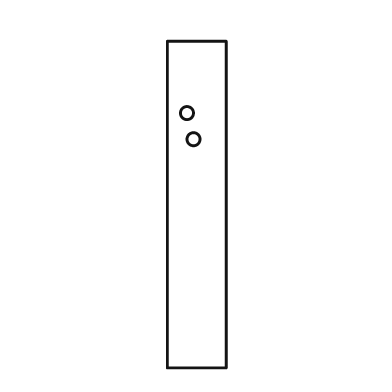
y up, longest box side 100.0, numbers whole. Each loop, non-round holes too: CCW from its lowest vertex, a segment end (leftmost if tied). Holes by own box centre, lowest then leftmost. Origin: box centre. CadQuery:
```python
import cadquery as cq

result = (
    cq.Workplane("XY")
    .moveTo(-9.0, -50.0)
    .lineTo(9.0, -50.0)
    .lineTo(9.0, 50.0)
    .lineTo(-9.0, 50.0)
    .close()
    .moveTo(-1.0, 20.0)
    .circle(2.0)
    .moveTo(-3.0, 28.0)
    .circle(2.0)
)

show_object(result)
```